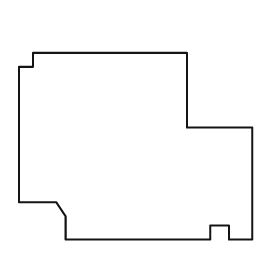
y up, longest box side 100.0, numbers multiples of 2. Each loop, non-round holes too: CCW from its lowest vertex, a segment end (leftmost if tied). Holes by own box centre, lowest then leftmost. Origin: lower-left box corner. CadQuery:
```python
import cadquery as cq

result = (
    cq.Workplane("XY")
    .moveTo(20.0, 0.0)
    .lineTo(82.0, 0.0)
    .lineTo(82.0, 6.0)
    .lineTo(90.0, 6.0)
    .lineTo(90.0, 0.0)
    .lineTo(100.0, 0.0)
    .lineTo(100.0, 48.0)
    .lineTo(72.0, 48.0)
    .lineTo(72.0, 80.0)
    .lineTo(6.0, 80.0)
    .lineTo(6.0, 74.0)
    .lineTo(0.0, 74.0)
    .lineTo(0.0, 16.0)
    .lineTo(16.0, 16.0)
    .lineTo(20.0, 10.0)
    .close()
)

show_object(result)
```